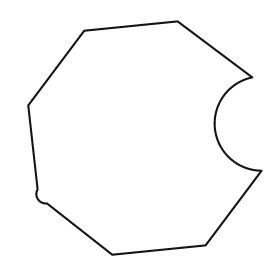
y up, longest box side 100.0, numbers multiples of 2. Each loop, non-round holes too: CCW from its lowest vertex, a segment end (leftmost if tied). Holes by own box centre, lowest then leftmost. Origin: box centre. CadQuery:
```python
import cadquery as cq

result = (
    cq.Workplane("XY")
    .moveTo(-14.0, -50.0)
    .lineTo(26.0, -46.0)
    .lineTo(50.0, -14.0)
    .threePointArc((30.0, 4.0), (46.0, 26.0))
    .lineTo(14.0, 50.0)
    .lineTo(-26.0, 46.0)
    .lineTo(-50.0, 14.0)
    .lineTo(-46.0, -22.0)
    .threePointArc((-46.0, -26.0), (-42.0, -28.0))
    .close()
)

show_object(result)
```